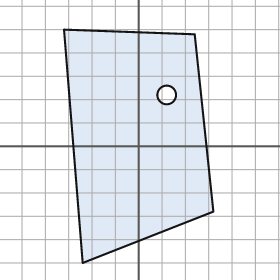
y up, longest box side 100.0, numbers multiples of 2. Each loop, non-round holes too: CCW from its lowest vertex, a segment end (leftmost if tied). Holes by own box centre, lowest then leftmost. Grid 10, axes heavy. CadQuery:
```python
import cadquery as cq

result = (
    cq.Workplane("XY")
    .moveTo(-24.0, -50.0)
    .lineTo(32.0, -28.0)
    .lineTo(24.0, 48.0)
    .lineTo(-32.0, 50.0)
    .close()
    .moveTo(12.0, 22.0)
    .circle(4.0)
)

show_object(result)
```